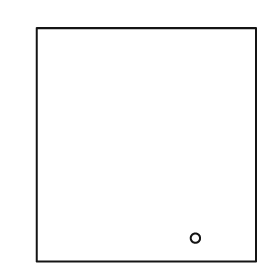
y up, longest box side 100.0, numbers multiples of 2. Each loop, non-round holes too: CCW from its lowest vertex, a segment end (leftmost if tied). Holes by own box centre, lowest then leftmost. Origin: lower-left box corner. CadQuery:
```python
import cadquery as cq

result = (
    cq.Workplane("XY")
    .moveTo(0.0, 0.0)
    .lineTo(94.0, 0.0)
    .lineTo(94.0, 100.0)
    .lineTo(0.0, 100.0)
    .close()
    .moveTo(68.0, 10.0)
    .circle(2.0)
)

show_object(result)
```